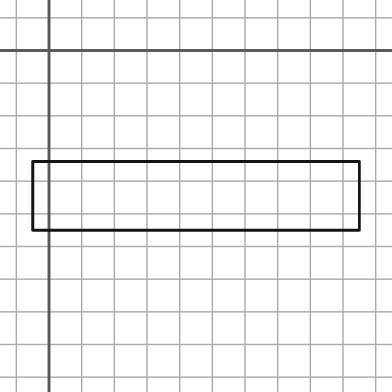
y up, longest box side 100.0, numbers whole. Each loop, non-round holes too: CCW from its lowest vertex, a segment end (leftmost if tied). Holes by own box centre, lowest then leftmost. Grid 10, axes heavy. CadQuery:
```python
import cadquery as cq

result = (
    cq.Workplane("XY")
    .moveTo(-5.0, -55.0)
    .lineTo(95.0, -55.0)
    .lineTo(95.0, -34.0)
    .lineTo(-5.0, -34.0)
    .close()
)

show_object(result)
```